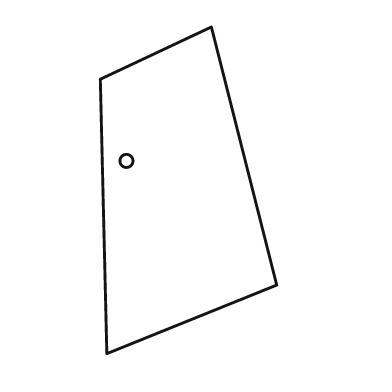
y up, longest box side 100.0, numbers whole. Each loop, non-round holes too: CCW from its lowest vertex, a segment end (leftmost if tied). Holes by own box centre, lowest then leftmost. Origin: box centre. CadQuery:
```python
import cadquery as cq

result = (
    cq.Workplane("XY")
    .moveTo(-25.0, -50.0)
    .lineTo(27.0, -29.0)
    .lineTo(7.0, 50.0)
    .lineTo(-27.0, 34.0)
    .close()
    .moveTo(-19.0, 9.0)
    .circle(2.0)
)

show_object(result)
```